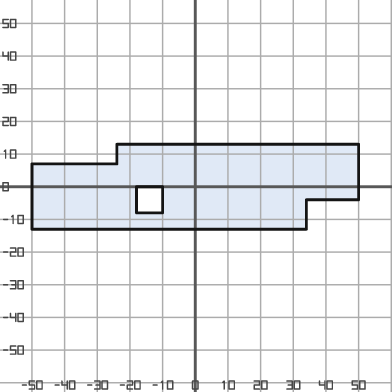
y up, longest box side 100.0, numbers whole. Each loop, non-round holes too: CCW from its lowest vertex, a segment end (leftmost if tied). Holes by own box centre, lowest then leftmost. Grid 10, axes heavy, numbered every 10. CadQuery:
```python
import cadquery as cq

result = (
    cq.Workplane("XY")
    .moveTo(-50.0, -13.0)
    .lineTo(34.0, -13.0)
    .lineTo(34.0, -4.0)
    .lineTo(50.0, -4.0)
    .lineTo(50.0, 13.0)
    .lineTo(-24.0, 13.0)
    .lineTo(-24.0, 7.0)
    .lineTo(-50.0, 7.0)
    .close()
    .moveTo(-18.0, -8.0)
    .lineTo(-10.0, -8.0)
    .lineTo(-10.0, 0.0)
    .lineTo(-18.0, 0.0)
    .close()
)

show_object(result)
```